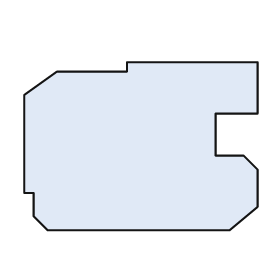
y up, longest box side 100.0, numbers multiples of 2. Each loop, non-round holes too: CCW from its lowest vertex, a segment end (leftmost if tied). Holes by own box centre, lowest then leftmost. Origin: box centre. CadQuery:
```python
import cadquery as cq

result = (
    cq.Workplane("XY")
    .moveTo(-40.0, -36.0)
    .lineTo(38.0, -36.0)
    .lineTo(50.0, -26.0)
    .lineTo(50.0, -10.0)
    .lineTo(44.0, -4.0)
    .lineTo(32.0, -4.0)
    .lineTo(32.0, 14.0)
    .lineTo(50.0, 14.0)
    .lineTo(50.0, 36.0)
    .lineTo(-6.0, 36.0)
    .lineTo(-6.0, 32.0)
    .lineTo(-36.0, 32.0)
    .lineTo(-50.0, 22.0)
    .lineTo(-50.0, -20.0)
    .lineTo(-46.0, -20.0)
    .lineTo(-46.0, -30.0)
    .close()
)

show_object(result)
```